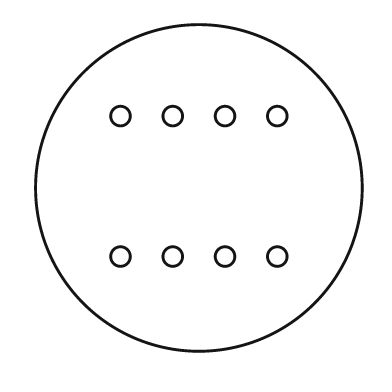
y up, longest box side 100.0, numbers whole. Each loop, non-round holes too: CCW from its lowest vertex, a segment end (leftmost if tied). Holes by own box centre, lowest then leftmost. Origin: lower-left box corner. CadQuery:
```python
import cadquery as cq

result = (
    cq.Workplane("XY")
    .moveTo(50.0, 50.0)
    .circle(50.0)
    .moveTo(26.0, 29.0)
    .circle(3.0)
    .moveTo(42.0, 29.0)
    .circle(3.0)
    .moveTo(58.0, 29.0)
    .circle(3.0)
    .moveTo(74.0, 29.0)
    .circle(3.0)
    .moveTo(26.0, 72.0)
    .circle(3.0)
    .moveTo(42.0, 72.0)
    .circle(3.0)
    .moveTo(58.0, 72.0)
    .circle(3.0)
    .moveTo(74.0, 72.0)
    .circle(3.0)
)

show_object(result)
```